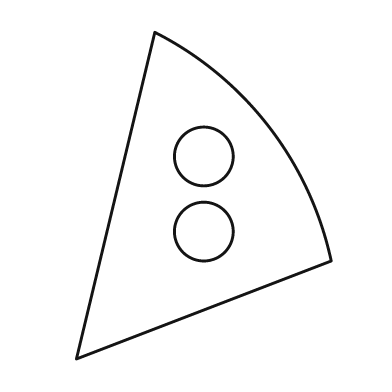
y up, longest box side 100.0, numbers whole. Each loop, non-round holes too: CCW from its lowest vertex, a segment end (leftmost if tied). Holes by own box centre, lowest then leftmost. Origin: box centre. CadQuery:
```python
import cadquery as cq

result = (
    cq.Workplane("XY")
    .moveTo(-39.0, -50.0)
    .lineTo(39.0, -20.0)
    .threePointArc((20.0, 21.0), (-15.0, 50.0))
    .close()
    .moveTo(0.0, -11.0)
    .circle(9.0)
    .moveTo(0.0, 12.0)
    .circle(9.0)
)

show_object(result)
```